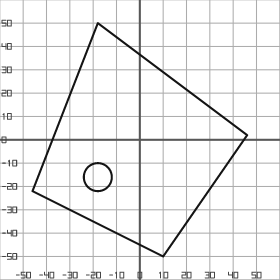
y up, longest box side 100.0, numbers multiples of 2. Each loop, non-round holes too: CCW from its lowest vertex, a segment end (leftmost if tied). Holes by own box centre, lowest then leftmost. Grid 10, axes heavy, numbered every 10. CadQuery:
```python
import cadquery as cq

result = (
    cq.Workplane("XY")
    .moveTo(10.0, -50.0)
    .lineTo(46.0, 2.0)
    .lineTo(-18.0, 50.0)
    .lineTo(-46.0, -22.0)
    .close()
    .moveTo(-18.0, -16.0)
    .circle(6.0)
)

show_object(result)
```